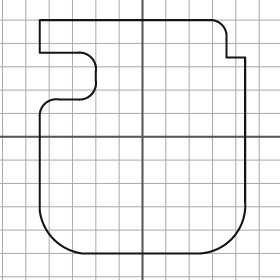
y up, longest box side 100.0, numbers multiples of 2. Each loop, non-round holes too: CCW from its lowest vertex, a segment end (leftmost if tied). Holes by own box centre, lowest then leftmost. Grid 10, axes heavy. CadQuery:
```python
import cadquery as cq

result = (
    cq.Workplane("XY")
    .moveTo(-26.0, -50.0)
    .lineTo(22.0, -50.0)
    .threePointArc((38.0, -44.0), (44.0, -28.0))
    .lineTo(44.0, 34.0)
    .lineTo(36.0, 34.0)
    .lineTo(36.0, 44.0)
    .threePointArc((34.0, 48.0), (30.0, 50.0))
    .lineTo(-44.0, 50.0)
    .lineTo(-44.0, 36.0)
    .lineTo(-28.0, 36.0)
    .threePointArc((-22.0, 34.0), (-20.0, 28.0))
    .lineTo(-20.0, 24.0)
    .threePointArc((-22.0, 18.0), (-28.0, 16.0))
    .lineTo(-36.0, 16.0)
    .threePointArc((-42.0, 14.0), (-44.0, 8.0))
    .lineTo(-44.0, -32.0)
    .threePointArc((-38.0, -44.0), (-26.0, -50.0))
    .close()
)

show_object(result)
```